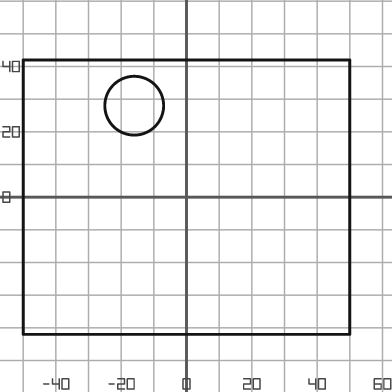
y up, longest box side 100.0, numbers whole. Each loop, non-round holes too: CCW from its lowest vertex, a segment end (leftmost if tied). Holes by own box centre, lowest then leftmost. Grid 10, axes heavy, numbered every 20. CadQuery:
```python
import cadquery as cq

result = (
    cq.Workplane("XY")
    .moveTo(-50.0, -42.0)
    .lineTo(50.0, -42.0)
    .lineTo(50.0, 42.0)
    .lineTo(-50.0, 42.0)
    .close()
    .moveTo(-16.0, 28.0)
    .circle(9.0)
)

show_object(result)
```